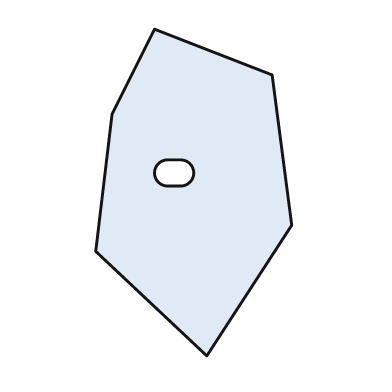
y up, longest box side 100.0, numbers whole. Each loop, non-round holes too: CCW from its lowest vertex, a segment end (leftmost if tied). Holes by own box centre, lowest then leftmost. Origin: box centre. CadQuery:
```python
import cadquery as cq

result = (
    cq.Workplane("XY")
    .moveTo(4.0, -50.0)
    .lineTo(30.0, -10.0)
    .lineTo(24.0, 36.0)
    .lineTo(-12.0, 50.0)
    .lineTo(-25.0, 24.0)
    .lineTo(-30.0, -18.0)
    .close()
    .moveTo(-8.0, 2.0)
    .lineTo(-4.0, 2.0)
    .threePointArc((0.0, 6.0), (-4.0, 10.0))
    .lineTo(-8.0, 10.0)
    .threePointArc((-12.0, 6.0), (-8.0, 2.0))
    .close()
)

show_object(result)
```